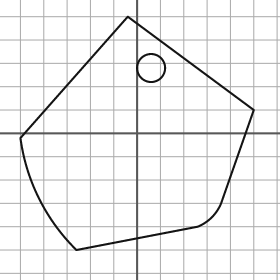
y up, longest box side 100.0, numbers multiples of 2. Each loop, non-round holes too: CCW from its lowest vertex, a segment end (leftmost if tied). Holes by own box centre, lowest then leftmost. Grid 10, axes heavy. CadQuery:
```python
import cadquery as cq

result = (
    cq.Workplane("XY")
    .moveTo(-26.0, -50.0)
    .lineTo(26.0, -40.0)
    .threePointArc((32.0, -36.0), (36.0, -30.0))
    .lineTo(50.0, 10.0)
    .lineTo(-4.0, 50.0)
    .lineTo(-50.0, -2.0)
    .threePointArc((-42.0, -28.0), (-26.0, -50.0))
    .close()
    .moveTo(6.0, 28.0)
    .circle(6.0)
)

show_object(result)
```